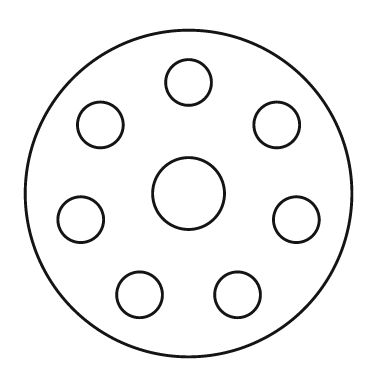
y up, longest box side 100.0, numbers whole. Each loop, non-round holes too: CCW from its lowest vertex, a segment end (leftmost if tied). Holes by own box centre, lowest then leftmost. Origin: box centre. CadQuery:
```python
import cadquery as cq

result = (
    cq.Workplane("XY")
    .moveTo(0.0, 0.0)
    .circle(50.0)
    .moveTo(-15.0, -31.0)
    .circle(7.0)
    .moveTo(15.0, -31.0)
    .circle(7.0)
    .moveTo(-33.0, -8.0)
    .circle(7.0)
    .moveTo(33.0, -8.0)
    .circle(7.0)
    .moveTo(0.0, 0.0)
    .circle(11.0)
    .moveTo(-27.0, 21.0)
    .circle(7.0)
    .moveTo(27.0, 21.0)
    .circle(7.0)
    .moveTo(0.0, 34.0)
    .circle(7.0)
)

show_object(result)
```